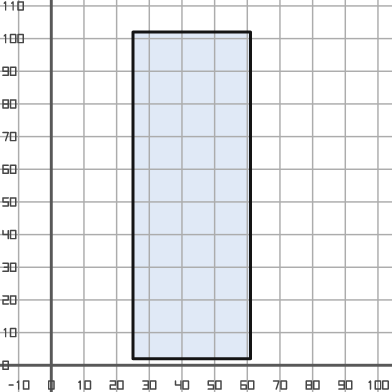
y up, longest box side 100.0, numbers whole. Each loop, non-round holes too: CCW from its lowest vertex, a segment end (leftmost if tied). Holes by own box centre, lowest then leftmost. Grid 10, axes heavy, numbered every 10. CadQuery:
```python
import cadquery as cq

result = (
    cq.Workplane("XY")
    .moveTo(25.0, 2.0)
    .lineTo(61.0, 2.0)
    .lineTo(61.0, 102.0)
    .lineTo(25.0, 102.0)
    .close()
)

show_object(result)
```